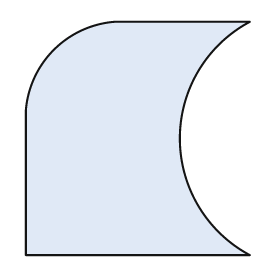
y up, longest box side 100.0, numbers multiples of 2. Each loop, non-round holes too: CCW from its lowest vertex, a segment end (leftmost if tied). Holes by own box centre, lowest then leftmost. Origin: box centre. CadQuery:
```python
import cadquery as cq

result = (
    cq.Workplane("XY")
    .moveTo(-48.0, -50.0)
    .lineTo(48.0, -50.0)
    .threePointArc((18.0, 0.0), (48.0, 50.0))
    .lineTo(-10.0, 50.0)
    .threePointArc((-36.0, 38.0), (-48.0, 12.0))
    .close()
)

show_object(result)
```